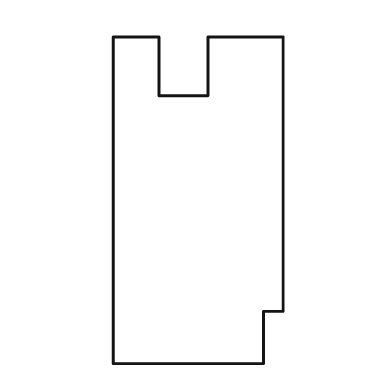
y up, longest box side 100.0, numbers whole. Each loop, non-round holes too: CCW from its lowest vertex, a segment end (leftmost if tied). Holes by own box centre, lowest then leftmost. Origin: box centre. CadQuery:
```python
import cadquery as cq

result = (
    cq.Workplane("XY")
    .moveTo(-26.0, -50.0)
    .lineTo(20.0, -50.0)
    .lineTo(20.0, -34.0)
    .lineTo(26.0, -34.0)
    .lineTo(26.0, 50.0)
    .lineTo(3.0, 50.0)
    .lineTo(3.0, 32.0)
    .lineTo(-12.0, 32.0)
    .lineTo(-12.0, 50.0)
    .lineTo(-26.0, 50.0)
    .close()
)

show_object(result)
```